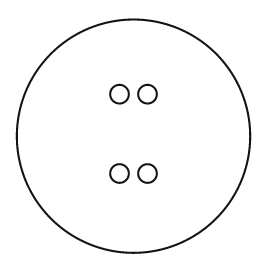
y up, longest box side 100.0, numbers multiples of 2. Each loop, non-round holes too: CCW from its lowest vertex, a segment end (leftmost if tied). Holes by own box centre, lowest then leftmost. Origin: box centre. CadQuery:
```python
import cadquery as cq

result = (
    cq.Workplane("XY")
    .moveTo(0.0, 0.0)
    .circle(50.0)
    .moveTo(-6.0, -16.0)
    .circle(4.0)
    .moveTo(6.0, -16.0)
    .circle(4.0)
    .moveTo(-6.0, 18.0)
    .circle(4.0)
    .moveTo(6.0, 18.0)
    .circle(4.0)
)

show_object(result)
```